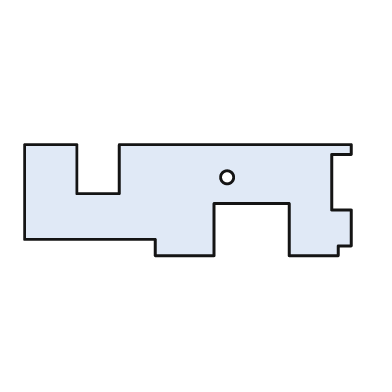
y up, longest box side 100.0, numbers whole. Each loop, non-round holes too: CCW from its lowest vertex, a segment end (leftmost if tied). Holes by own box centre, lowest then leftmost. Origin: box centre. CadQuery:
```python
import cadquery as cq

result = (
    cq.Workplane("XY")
    .moveTo(-10.0, -17.0)
    .lineTo(8.0, -17.0)
    .lineTo(8.0, -1.0)
    .lineTo(31.0, -1.0)
    .lineTo(31.0, -17.0)
    .lineTo(46.0, -17.0)
    .lineTo(46.0, -14.0)
    .lineTo(50.0, -14.0)
    .lineTo(50.0, -3.0)
    .lineTo(44.0, -3.0)
    .lineTo(44.0, 14.0)
    .lineTo(50.0, 14.0)
    .lineTo(50.0, 17.0)
    .lineTo(-21.0, 17.0)
    .lineTo(-21.0, 2.0)
    .lineTo(-34.0, 2.0)
    .lineTo(-34.0, 17.0)
    .lineTo(-50.0, 17.0)
    .lineTo(-50.0, -12.0)
    .lineTo(-10.0, -12.0)
    .close()
    .moveTo(12.0, 7.0)
    .circle(2.0)
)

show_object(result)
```